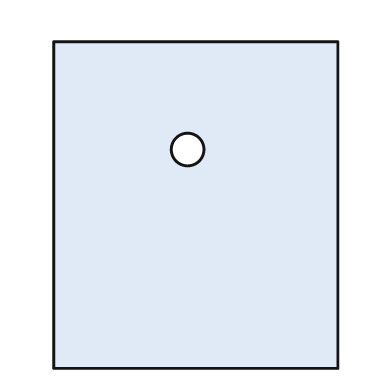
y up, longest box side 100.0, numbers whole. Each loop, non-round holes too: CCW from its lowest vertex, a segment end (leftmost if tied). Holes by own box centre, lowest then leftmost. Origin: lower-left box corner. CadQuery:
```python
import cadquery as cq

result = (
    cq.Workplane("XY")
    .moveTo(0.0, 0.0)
    .lineTo(87.0, 0.0)
    .lineTo(87.0, 100.0)
    .lineTo(0.0, 100.0)
    .close()
    .moveTo(41.0, 67.0)
    .circle(5.0)
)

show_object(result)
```